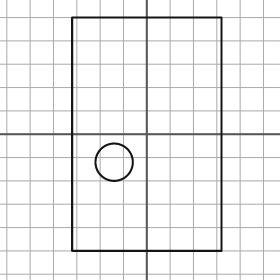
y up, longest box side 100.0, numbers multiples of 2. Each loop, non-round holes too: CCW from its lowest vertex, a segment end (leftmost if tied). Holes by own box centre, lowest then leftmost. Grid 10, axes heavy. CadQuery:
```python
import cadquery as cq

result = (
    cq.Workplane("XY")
    .moveTo(-32.0, -50.0)
    .lineTo(32.0, -50.0)
    .lineTo(32.0, 50.0)
    .lineTo(-32.0, 50.0)
    .close()
    .moveTo(-14.0, -12.0)
    .circle(8.0)
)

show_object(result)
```